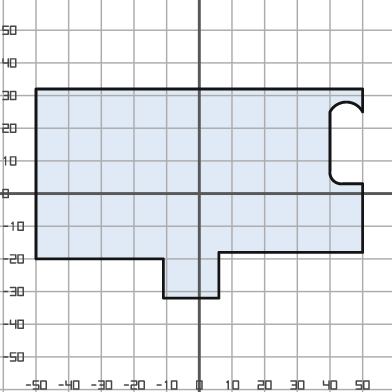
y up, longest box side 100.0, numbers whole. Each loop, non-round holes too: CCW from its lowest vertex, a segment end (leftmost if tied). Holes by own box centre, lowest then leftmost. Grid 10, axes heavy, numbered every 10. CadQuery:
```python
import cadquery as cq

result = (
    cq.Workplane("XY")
    .moveTo(-11.0, -32.0)
    .lineTo(6.0, -32.0)
    .lineTo(6.0, -18.0)
    .lineTo(50.0, -18.0)
    .lineTo(50.0, 3.0)
    .lineTo(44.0, 3.0)
    .threePointArc((41.0, 4.0), (40.0, 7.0))
    .lineTo(40.0, 25.0)
    .threePointArc((45.0, 28.0), (50.0, 25.0))
    .lineTo(50.0, 32.0)
    .lineTo(-50.0, 32.0)
    .lineTo(-50.0, -20.0)
    .lineTo(-11.0, -20.0)
    .close()
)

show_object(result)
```